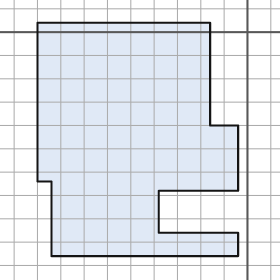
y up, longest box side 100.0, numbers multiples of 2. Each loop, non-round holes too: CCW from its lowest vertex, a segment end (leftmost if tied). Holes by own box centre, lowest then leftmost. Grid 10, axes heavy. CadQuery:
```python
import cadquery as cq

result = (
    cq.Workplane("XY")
    .moveTo(-84.0, -96.0)
    .lineTo(-4.0, -96.0)
    .lineTo(-4.0, -86.0)
    .lineTo(-38.0, -86.0)
    .lineTo(-38.0, -68.0)
    .lineTo(-4.0, -68.0)
    .lineTo(-4.0, -40.0)
    .lineTo(-16.0, -40.0)
    .lineTo(-16.0, 4.0)
    .lineTo(-90.0, 4.0)
    .lineTo(-90.0, -64.0)
    .lineTo(-84.0, -64.0)
    .close()
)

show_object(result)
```